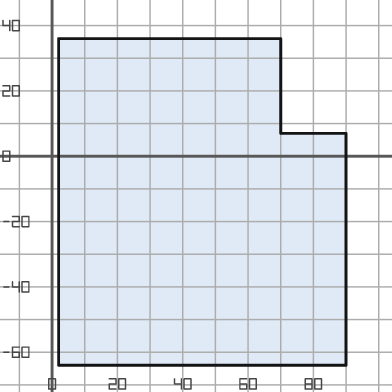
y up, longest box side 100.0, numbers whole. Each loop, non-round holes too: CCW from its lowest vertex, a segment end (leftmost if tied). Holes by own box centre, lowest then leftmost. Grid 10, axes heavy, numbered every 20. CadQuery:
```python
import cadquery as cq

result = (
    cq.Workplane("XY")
    .moveTo(2.0, -64.0)
    .lineTo(90.0, -64.0)
    .lineTo(90.0, 7.0)
    .lineTo(70.0, 7.0)
    .lineTo(70.0, 36.0)
    .lineTo(2.0, 36.0)
    .close()
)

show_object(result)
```